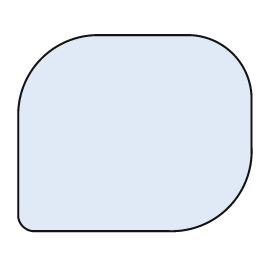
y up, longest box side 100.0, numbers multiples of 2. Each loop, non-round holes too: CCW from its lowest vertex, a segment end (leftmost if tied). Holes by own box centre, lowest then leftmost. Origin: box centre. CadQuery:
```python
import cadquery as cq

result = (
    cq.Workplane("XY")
    .moveTo(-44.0, -42.0)
    .lineTo(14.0, -42.0)
    .threePointArc((40.0, -32.0), (50.0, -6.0))
    .lineTo(50.0, 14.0)
    .threePointArc((42.0, 34.0), (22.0, 42.0))
    .lineTo(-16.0, 42.0)
    .threePointArc((-40.0, 32.0), (-50.0, 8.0))
    .lineTo(-50.0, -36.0)
    .threePointArc((-48.0, -40.0), (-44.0, -42.0))
    .close()
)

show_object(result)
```